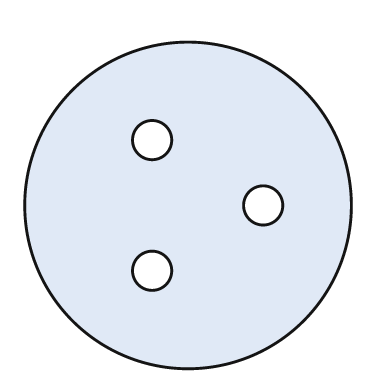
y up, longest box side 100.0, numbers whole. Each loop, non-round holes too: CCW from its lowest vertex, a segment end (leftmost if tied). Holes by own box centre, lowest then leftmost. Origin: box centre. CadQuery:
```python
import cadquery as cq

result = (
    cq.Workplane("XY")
    .moveTo(0.0, 0.0)
    .circle(50.0)
    .moveTo(-11.0, -20.0)
    .circle(6.0)
    .moveTo(23.0, 0.0)
    .circle(6.0)
    .moveTo(-11.0, 20.0)
    .circle(6.0)
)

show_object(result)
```